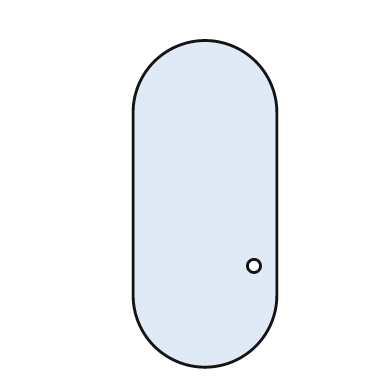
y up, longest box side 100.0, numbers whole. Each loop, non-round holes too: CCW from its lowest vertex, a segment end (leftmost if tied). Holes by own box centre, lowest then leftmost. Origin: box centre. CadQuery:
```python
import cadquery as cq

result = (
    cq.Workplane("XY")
    .moveTo(-22.0, -28.0)
    .threePointArc((0.0, -50.0), (22.0, -28.0))
    .lineTo(22.0, 28.0)
    .threePointArc((0.0, 50.0), (-22.0, 28.0))
    .close()
    .moveTo(15.0, -19.0)
    .circle(2.0)
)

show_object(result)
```